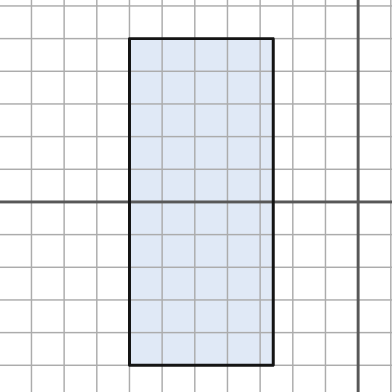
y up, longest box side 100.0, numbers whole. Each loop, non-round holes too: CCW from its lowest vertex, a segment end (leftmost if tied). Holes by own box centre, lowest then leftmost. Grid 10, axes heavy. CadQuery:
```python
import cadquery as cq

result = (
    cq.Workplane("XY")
    .moveTo(-70.0, -50.0)
    .lineTo(-26.0, -50.0)
    .lineTo(-26.0, 50.0)
    .lineTo(-70.0, 50.0)
    .close()
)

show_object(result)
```